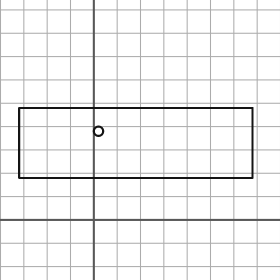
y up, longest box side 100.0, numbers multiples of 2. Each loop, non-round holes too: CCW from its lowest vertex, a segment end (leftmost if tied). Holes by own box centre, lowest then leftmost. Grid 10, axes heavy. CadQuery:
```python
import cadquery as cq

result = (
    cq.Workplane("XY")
    .moveTo(-32.0, 18.0)
    .lineTo(68.0, 18.0)
    .lineTo(68.0, 48.0)
    .lineTo(-32.0, 48.0)
    .close()
    .moveTo(2.0, 38.0)
    .circle(2.0)
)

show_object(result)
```